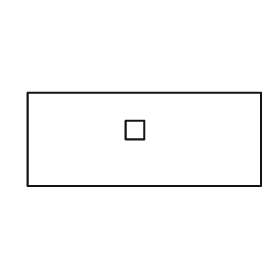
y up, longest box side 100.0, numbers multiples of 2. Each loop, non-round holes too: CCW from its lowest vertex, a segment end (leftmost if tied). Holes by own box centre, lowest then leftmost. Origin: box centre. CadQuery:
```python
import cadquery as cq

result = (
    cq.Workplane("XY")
    .moveTo(-50.0, -20.0)
    .lineTo(50.0, -20.0)
    .lineTo(50.0, 20.0)
    .lineTo(-50.0, 20.0)
    .close()
    .moveTo(-8.0, 0.0)
    .lineTo(0.0, 0.0)
    .lineTo(0.0, 8.0)
    .lineTo(-8.0, 8.0)
    .close()
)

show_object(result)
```